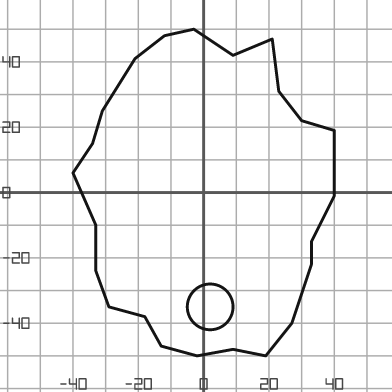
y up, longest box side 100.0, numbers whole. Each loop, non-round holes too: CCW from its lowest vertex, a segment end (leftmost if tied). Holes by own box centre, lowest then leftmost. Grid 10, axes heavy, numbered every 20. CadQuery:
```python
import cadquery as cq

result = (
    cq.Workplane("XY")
    .moveTo(-2.0, -50.0)
    .lineTo(9.0, -48.0)
    .lineTo(19.0, -50.0)
    .lineTo(27.0, -40.0)
    .lineTo(33.0, -22.0)
    .lineTo(33.0, -15.0)
    .lineTo(40.0, -1.0)
    .lineTo(40.0, 19.0)
    .lineTo(30.0, 22.0)
    .lineTo(23.0, 31.0)
    .lineTo(21.0, 47.0)
    .lineTo(9.0, 42.0)
    .lineTo(-3.0, 50.0)
    .lineTo(-12.0, 48.0)
    .lineTo(-21.0, 41.0)
    .lineTo(-31.0, 25.0)
    .lineTo(-34.0, 15.0)
    .lineTo(-40.0, 6.0)
    .lineTo(-33.0, -10.0)
    .lineTo(-33.0, -24.0)
    .lineTo(-29.0, -35.0)
    .lineTo(-18.0, -38.0)
    .lineTo(-13.0, -47.0)
    .close()
    .moveTo(2.0, -35.0)
    .circle(7.0)
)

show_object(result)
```